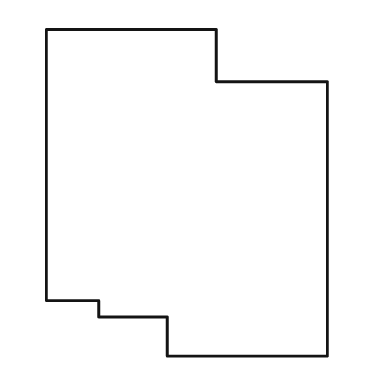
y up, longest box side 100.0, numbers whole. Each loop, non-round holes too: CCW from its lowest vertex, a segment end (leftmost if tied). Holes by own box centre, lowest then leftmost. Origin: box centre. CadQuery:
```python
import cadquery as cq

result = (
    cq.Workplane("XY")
    .moveTo(-6.0, -50.0)
    .lineTo(43.0, -50.0)
    .lineTo(43.0, 34.0)
    .lineTo(9.0, 34.0)
    .lineTo(9.0, 50.0)
    .lineTo(-43.0, 50.0)
    .lineTo(-43.0, -33.0)
    .lineTo(-27.0, -33.0)
    .lineTo(-27.0, -38.0)
    .lineTo(-6.0, -38.0)
    .close()
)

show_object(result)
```